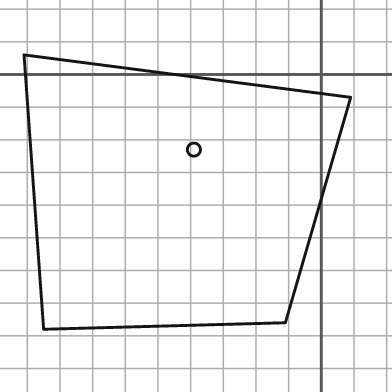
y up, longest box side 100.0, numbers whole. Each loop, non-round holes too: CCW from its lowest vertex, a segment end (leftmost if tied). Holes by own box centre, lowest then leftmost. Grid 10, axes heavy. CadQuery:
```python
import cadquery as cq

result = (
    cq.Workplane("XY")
    .moveTo(-85.0, -78.0)
    .lineTo(-11.0, -76.0)
    .lineTo(9.0, -7.0)
    .lineTo(-91.0, 6.0)
    .close()
    .moveTo(-39.0, -23.0)
    .circle(2.0)
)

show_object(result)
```